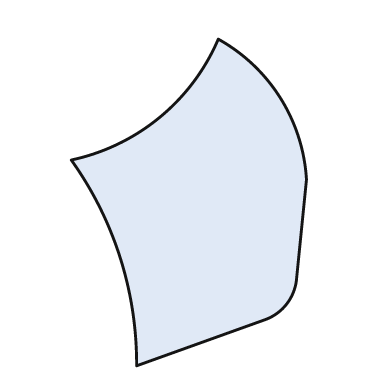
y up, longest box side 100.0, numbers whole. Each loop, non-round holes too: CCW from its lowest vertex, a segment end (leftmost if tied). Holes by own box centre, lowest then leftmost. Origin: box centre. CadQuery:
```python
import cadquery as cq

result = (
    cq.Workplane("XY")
    .moveTo(-16.0, -50.0)
    .lineTo(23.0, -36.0)
    .threePointArc((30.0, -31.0), (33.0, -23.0))
    .lineTo(36.0, 7.0)
    .threePointArc((28.0, 32.0), (9.0, 50.0))
    .threePointArc((-9.0, 26.0), (-36.0, 13.0))
    .threePointArc((-21.0, -17.0), (-16.0, -50.0))
    .close()
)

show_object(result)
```